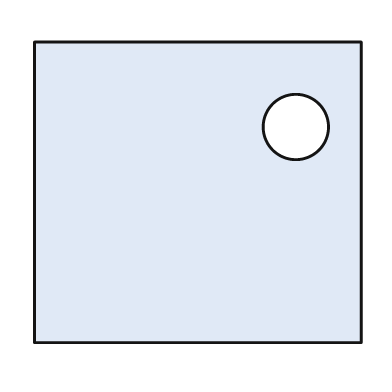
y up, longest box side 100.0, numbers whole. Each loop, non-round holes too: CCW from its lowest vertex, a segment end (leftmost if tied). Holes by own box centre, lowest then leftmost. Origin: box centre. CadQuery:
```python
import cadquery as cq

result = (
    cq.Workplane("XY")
    .moveTo(-50.0, -46.0)
    .lineTo(50.0, -46.0)
    .lineTo(50.0, 46.0)
    .lineTo(-50.0, 46.0)
    .close()
    .moveTo(30.0, 20.0)
    .circle(10.0)
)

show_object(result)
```